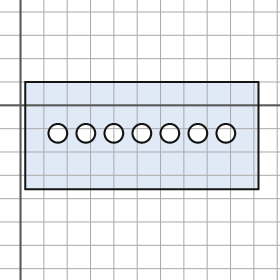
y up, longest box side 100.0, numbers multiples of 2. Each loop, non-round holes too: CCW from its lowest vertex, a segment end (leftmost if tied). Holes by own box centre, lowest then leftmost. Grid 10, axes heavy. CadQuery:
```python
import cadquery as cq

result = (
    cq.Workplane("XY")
    .moveTo(2.0, -36.0)
    .lineTo(102.0, -36.0)
    .lineTo(102.0, 10.0)
    .lineTo(2.0, 10.0)
    .close()
    .moveTo(16.0, -12.0)
    .circle(4.0)
    .moveTo(28.0, -12.0)
    .circle(4.0)
    .moveTo(40.0, -12.0)
    .circle(4.0)
    .moveTo(52.0, -12.0)
    .circle(4.0)
    .moveTo(64.0, -12.0)
    .circle(4.0)
    .moveTo(76.0, -12.0)
    .circle(4.0)
    .moveTo(88.0, -12.0)
    .circle(4.0)
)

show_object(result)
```